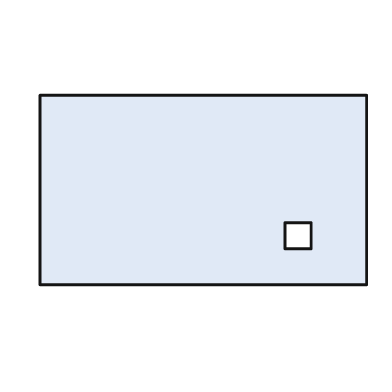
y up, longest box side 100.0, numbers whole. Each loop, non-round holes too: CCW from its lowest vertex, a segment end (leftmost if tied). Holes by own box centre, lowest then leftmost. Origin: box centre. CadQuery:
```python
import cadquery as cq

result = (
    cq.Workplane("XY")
    .moveTo(-50.0, -29.0)
    .lineTo(50.0, -29.0)
    .lineTo(50.0, 29.0)
    .lineTo(-50.0, 29.0)
    .close()
    .moveTo(25.0, -18.0)
    .lineTo(33.0, -18.0)
    .lineTo(33.0, -10.0)
    .lineTo(25.0, -10.0)
    .close()
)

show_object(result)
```